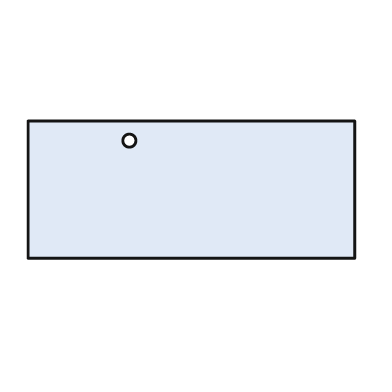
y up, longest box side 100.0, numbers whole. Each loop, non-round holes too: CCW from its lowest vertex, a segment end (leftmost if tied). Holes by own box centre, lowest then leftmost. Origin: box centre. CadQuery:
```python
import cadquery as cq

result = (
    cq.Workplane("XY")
    .moveTo(-50.0, -21.0)
    .lineTo(50.0, -21.0)
    .lineTo(50.0, 21.0)
    .lineTo(-50.0, 21.0)
    .close()
    .moveTo(-19.0, 15.0)
    .circle(2.0)
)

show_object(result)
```